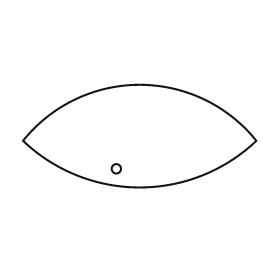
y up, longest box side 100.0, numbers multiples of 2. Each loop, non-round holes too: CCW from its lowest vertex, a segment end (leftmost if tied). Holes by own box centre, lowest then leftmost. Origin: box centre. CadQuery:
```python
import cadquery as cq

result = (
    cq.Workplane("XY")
    .moveTo(-50.0, -2.0)
    .threePointArc((0.0, -22.0), (50.0, -2.0))
    .threePointArc((0.0, 22.0), (-50.0, -2.0))
    .close()
    .moveTo(-10.0, -14.0)
    .circle(2.0)
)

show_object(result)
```